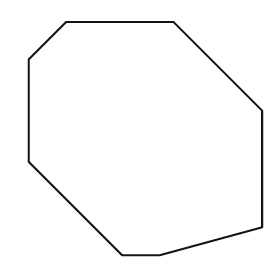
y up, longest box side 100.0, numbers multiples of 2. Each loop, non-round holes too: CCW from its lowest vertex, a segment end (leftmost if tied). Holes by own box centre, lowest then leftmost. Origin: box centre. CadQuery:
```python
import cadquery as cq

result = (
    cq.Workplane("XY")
    .moveTo(-10.0, -50.0)
    .lineTo(6.0, -50.0)
    .lineTo(50.0, -38.0)
    .lineTo(50.0, 12.0)
    .lineTo(12.0, 50.0)
    .lineTo(-34.0, 50.0)
    .lineTo(-50.0, 34.0)
    .lineTo(-50.0, -10.0)
    .close()
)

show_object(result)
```